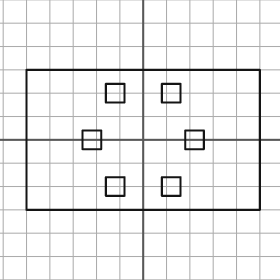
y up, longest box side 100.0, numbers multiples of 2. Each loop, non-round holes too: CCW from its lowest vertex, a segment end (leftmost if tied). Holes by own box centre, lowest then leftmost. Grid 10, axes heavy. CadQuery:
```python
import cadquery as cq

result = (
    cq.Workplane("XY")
    .moveTo(-50.0, -30.0)
    .lineTo(50.0, -30.0)
    .lineTo(50.0, 30.0)
    .lineTo(-50.0, 30.0)
    .close()
    .moveTo(-16.0, -24.0)
    .lineTo(-8.0, -24.0)
    .lineTo(-8.0, -16.0)
    .lineTo(-16.0, -16.0)
    .close()
    .moveTo(8.0, -24.0)
    .lineTo(16.0, -24.0)
    .lineTo(16.0, -16.0)
    .lineTo(8.0, -16.0)
    .close()
    .moveTo(-26.0, -4.0)
    .lineTo(-18.0, -4.0)
    .lineTo(-18.0, 4.0)
    .lineTo(-26.0, 4.0)
    .close()
    .moveTo(18.0, -4.0)
    .lineTo(26.0, -4.0)
    .lineTo(26.0, 4.0)
    .lineTo(18.0, 4.0)
    .close()
    .moveTo(-16.0, 16.0)
    .lineTo(-8.0, 16.0)
    .lineTo(-8.0, 24.0)
    .lineTo(-16.0, 24.0)
    .close()
    .moveTo(8.0, 16.0)
    .lineTo(16.0, 16.0)
    .lineTo(16.0, 24.0)
    .lineTo(8.0, 24.0)
    .close()
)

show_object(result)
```